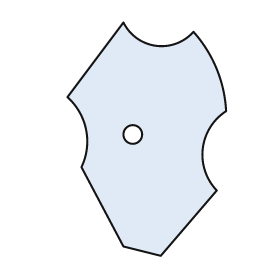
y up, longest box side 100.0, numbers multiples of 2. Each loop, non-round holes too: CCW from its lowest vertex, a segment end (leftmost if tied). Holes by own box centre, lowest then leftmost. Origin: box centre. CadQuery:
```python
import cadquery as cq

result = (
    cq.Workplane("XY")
    .moveTo(6.0, -50.0)
    .lineTo(30.0, -22.0)
    .threePointArc((24.0, -4.0), (34.0, 12.0))
    .threePointArc((30.0, 30.0), (20.0, 46.0))
    .threePointArc((4.0, 40.0), (-10.0, 50.0))
    .lineTo(-34.0, 18.0)
    .threePointArc((-26.0, 4.0), (-28.0, -12.0))
    .lineTo(-10.0, -46.0)
    .close()
    .moveTo(-6.0, 2.0)
    .circle(4.0)
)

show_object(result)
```